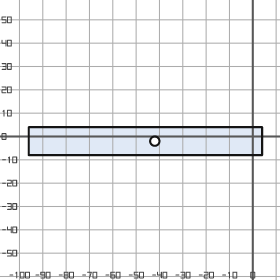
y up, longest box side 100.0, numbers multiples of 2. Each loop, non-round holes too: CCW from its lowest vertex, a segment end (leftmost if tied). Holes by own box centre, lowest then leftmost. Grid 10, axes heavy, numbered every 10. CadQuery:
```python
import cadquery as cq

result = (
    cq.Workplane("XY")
    .moveTo(-96.0, -8.0)
    .lineTo(4.0, -8.0)
    .lineTo(4.0, 4.0)
    .lineTo(-96.0, 4.0)
    .close()
    .moveTo(-42.0, -2.0)
    .circle(2.0)
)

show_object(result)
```